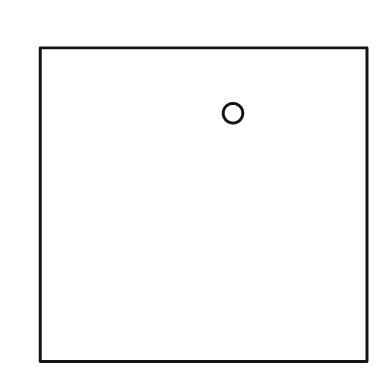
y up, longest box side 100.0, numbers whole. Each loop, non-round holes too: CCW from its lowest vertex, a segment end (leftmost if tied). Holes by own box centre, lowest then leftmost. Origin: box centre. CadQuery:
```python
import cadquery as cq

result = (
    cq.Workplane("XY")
    .moveTo(-50.0, -48.0)
    .lineTo(50.0, -48.0)
    .lineTo(50.0, 48.0)
    .lineTo(-50.0, 48.0)
    .close()
    .moveTo(9.0, 28.0)
    .circle(3.0)
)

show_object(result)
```